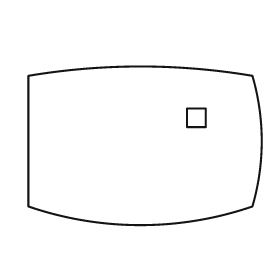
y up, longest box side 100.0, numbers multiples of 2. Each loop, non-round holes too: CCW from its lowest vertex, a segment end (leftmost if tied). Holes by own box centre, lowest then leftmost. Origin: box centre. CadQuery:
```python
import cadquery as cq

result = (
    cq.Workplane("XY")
    .moveTo(-50.0, -26.0)
    .threePointArc((-2.0, -34.0), (46.0, -26.0))
    .threePointArc((50.0, 2.0), (46.0, 30.0))
    .threePointArc((-2.0, 34.0), (-50.0, 30.0))
    .close()
    .moveTo(18.0, 8.0)
    .lineTo(26.0, 8.0)
    .lineTo(26.0, 16.0)
    .lineTo(18.0, 16.0)
    .close()
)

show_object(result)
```